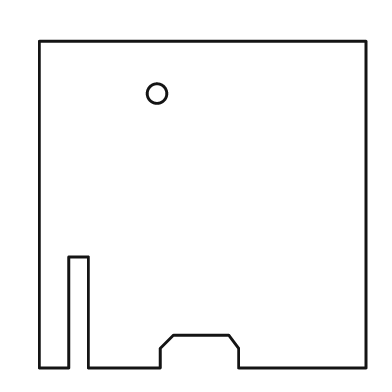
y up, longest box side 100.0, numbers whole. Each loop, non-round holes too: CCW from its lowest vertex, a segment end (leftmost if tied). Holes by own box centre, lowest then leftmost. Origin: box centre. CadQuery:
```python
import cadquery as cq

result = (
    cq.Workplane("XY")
    .moveTo(-50.0, -50.0)
    .lineTo(-41.0, -50.0)
    .lineTo(-41.0, -16.0)
    .lineTo(-35.0, -16.0)
    .lineTo(-35.0, -50.0)
    .lineTo(-13.0, -50.0)
    .lineTo(-13.0, -44.0)
    .lineTo(-9.0, -40.0)
    .lineTo(8.0, -40.0)
    .lineTo(11.0, -44.0)
    .lineTo(11.0, -50.0)
    .lineTo(50.0, -50.0)
    .lineTo(50.0, 50.0)
    .lineTo(-50.0, 50.0)
    .close()
    .moveTo(-14.0, 34.0)
    .circle(3.0)
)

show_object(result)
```